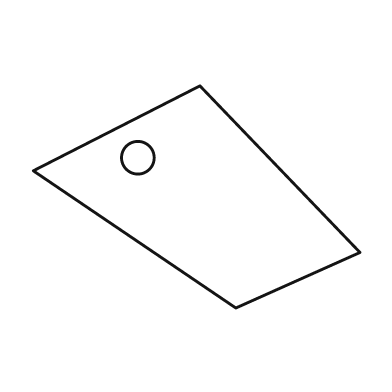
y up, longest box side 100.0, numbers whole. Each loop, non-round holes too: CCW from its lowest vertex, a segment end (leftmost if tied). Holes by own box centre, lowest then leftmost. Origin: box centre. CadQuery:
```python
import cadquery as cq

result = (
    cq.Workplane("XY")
    .moveTo(12.0, -34.0)
    .lineTo(50.0, -17.0)
    .lineTo(1.0, 34.0)
    .lineTo(-50.0, 8.0)
    .close()
    .moveTo(-18.0, 12.0)
    .circle(5.0)
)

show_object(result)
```